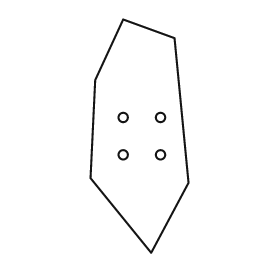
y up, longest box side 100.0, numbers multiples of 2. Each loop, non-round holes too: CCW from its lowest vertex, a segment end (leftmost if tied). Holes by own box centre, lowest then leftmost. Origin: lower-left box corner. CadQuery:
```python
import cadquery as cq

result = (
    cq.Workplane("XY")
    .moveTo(26.0, 0.0)
    .lineTo(42.0, 30.0)
    .lineTo(36.0, 92.0)
    .lineTo(14.0, 100.0)
    .lineTo(2.0, 74.0)
    .lineTo(0.0, 32.0)
    .close()
    .moveTo(14.0, 42.0)
    .circle(2.0)
    .moveTo(30.0, 42.0)
    .circle(2.0)
    .moveTo(14.0, 58.0)
    .circle(2.0)
    .moveTo(30.0, 58.0)
    .circle(2.0)
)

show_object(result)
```